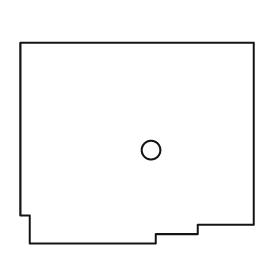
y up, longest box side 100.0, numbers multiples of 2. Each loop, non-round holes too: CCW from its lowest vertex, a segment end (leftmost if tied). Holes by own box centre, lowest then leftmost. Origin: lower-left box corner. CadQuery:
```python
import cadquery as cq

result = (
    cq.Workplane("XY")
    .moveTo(4.0, 0.0)
    .lineTo(58.0, 0.0)
    .lineTo(58.0, 4.0)
    .lineTo(76.0, 4.0)
    .lineTo(76.0, 8.0)
    .lineTo(100.0, 8.0)
    .lineTo(100.0, 86.0)
    .lineTo(0.0, 86.0)
    .lineTo(0.0, 12.0)
    .lineTo(4.0, 12.0)
    .close()
    .moveTo(56.0, 40.0)
    .circle(4.0)
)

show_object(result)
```